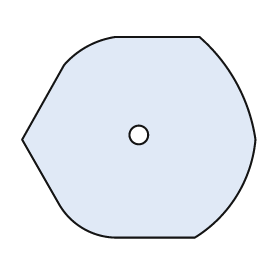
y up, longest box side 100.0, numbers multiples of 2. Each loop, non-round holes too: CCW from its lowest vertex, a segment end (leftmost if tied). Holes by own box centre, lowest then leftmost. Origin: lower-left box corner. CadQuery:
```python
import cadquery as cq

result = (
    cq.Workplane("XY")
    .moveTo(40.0, 0.0)
    .lineTo(74.0, 0.0)
    .threePointArc((92.0, 18.0), (100.0, 42.0))
    .threePointArc((92.0, 66.0), (76.0, 86.0))
    .lineTo(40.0, 86.0)
    .threePointArc((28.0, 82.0), (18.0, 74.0))
    .lineTo(0.0, 42.0)
    .lineTo(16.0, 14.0)
    .threePointArc((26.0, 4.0), (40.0, 0.0))
    .close()
    .moveTo(50.0, 44.0)
    .circle(4.0)
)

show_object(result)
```